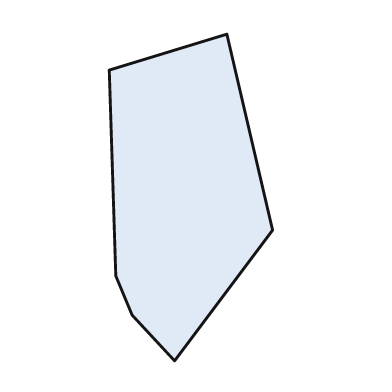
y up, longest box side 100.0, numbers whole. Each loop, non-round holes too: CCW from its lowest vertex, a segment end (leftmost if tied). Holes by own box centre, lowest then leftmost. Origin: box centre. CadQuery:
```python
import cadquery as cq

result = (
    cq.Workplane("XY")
    .moveTo(-5.0, -50.0)
    .lineTo(25.0, -10.0)
    .lineTo(11.0, 50.0)
    .lineTo(-25.0, 39.0)
    .lineTo(-23.0, -24.0)
    .lineTo(-18.0, -36.0)
    .close()
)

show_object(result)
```